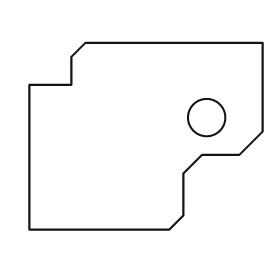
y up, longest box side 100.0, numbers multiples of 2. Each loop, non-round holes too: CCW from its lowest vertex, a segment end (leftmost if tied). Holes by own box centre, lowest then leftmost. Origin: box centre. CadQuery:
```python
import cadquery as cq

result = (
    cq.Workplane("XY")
    .moveTo(-50.0, -40.0)
    .lineTo(10.0, -40.0)
    .lineTo(16.0, -34.0)
    .lineTo(16.0, -16.0)
    .lineTo(24.0, -8.0)
    .lineTo(40.0, -8.0)
    .lineTo(50.0, 2.0)
    .lineTo(50.0, 40.0)
    .lineTo(-26.0, 40.0)
    .lineTo(-32.0, 34.0)
    .lineTo(-32.0, 22.0)
    .lineTo(-50.0, 22.0)
    .close()
    .moveTo(26.0, 8.0)
    .circle(8.0)
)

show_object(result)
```